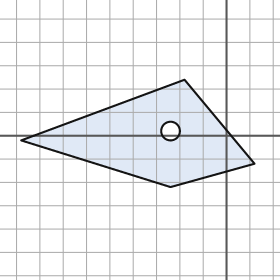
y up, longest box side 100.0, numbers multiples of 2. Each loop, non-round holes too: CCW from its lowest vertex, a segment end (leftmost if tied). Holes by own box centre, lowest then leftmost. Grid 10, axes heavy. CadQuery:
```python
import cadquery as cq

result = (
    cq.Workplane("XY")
    .moveTo(-24.0, -22.0)
    .lineTo(12.0, -12.0)
    .lineTo(-18.0, 24.0)
    .lineTo(-88.0, -2.0)
    .close()
    .moveTo(-24.0, 2.0)
    .circle(4.0)
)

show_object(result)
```